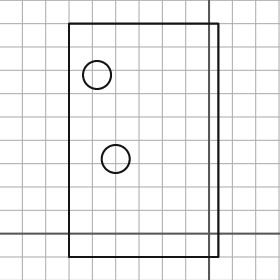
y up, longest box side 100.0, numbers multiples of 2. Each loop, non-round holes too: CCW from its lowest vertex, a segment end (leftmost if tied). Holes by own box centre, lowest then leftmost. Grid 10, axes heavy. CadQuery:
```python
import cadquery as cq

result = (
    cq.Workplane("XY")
    .moveTo(-60.0, -10.0)
    .lineTo(4.0, -10.0)
    .lineTo(4.0, 90.0)
    .lineTo(-60.0, 90.0)
    .close()
    .moveTo(-40.0, 32.0)
    .circle(6.0)
    .moveTo(-48.0, 68.0)
    .circle(6.0)
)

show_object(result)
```